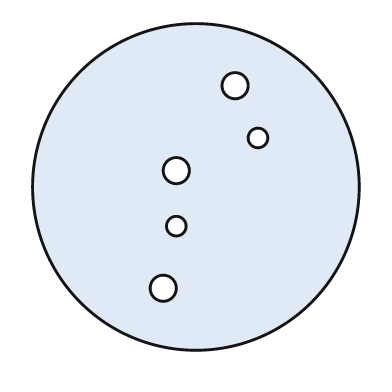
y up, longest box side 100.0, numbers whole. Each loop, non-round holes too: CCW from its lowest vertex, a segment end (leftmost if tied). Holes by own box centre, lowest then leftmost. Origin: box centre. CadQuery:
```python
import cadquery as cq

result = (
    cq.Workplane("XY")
    .moveTo(0.0, 0.0)
    .circle(50.0)
    .moveTo(-10.0, -31.0)
    .circle(4.0)
    .moveTo(-6.0, -12.0)
    .circle(3.0)
    .moveTo(-6.0, 5.0)
    .circle(4.0)
    .moveTo(19.0, 15.0)
    .circle(3.0)
    .moveTo(12.0, 31.0)
    .circle(4.0)
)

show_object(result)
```